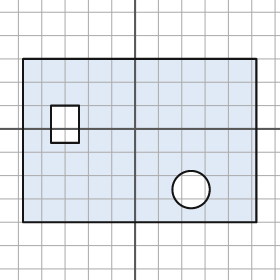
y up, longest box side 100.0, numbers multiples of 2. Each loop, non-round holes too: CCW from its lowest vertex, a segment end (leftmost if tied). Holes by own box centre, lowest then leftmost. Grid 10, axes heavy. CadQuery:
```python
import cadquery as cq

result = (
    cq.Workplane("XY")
    .moveTo(-48.0, -40.0)
    .lineTo(52.0, -40.0)
    .lineTo(52.0, 30.0)
    .lineTo(-48.0, 30.0)
    .close()
    .moveTo(24.0, -26.0)
    .circle(8.0)
    .moveTo(-36.0, -6.0)
    .lineTo(-24.0, -6.0)
    .lineTo(-24.0, 10.0)
    .lineTo(-36.0, 10.0)
    .close()
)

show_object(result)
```